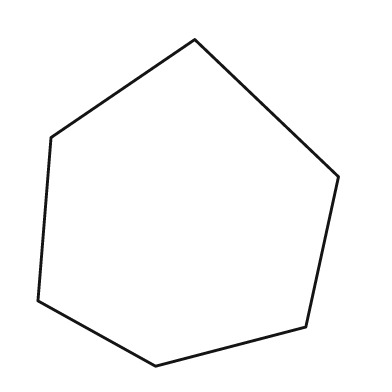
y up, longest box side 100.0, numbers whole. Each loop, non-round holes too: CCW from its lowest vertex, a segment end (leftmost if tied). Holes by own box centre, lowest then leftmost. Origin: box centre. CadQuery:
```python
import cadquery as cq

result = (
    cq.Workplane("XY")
    .moveTo(-10.0, -50.0)
    .lineTo(36.0, -38.0)
    .lineTo(46.0, 8.0)
    .lineTo(2.0, 50.0)
    .lineTo(-42.0, 20.0)
    .lineTo(-46.0, -30.0)
    .close()
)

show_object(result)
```